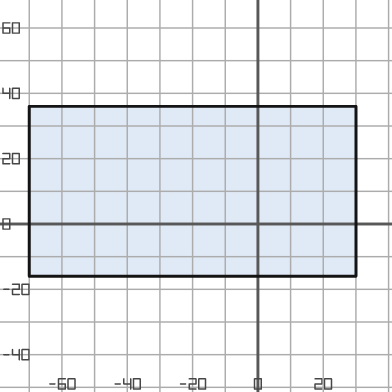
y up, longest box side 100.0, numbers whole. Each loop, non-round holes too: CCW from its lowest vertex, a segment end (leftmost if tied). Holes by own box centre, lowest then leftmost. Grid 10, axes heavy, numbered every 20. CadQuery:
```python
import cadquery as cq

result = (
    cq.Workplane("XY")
    .moveTo(-70.0, -16.0)
    .lineTo(30.0, -16.0)
    .lineTo(30.0, 36.0)
    .lineTo(-70.0, 36.0)
    .close()
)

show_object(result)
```